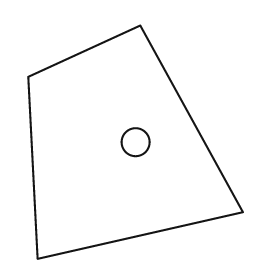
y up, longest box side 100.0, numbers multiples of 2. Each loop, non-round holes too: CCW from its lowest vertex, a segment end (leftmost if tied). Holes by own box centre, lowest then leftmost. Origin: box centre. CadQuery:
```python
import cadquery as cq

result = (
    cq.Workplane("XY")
    .moveTo(-42.0, -50.0)
    .lineTo(46.0, -30.0)
    .lineTo(2.0, 50.0)
    .lineTo(-46.0, 28.0)
    .close()
    .moveTo(0.0, 0.0)
    .circle(6.0)
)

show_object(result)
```